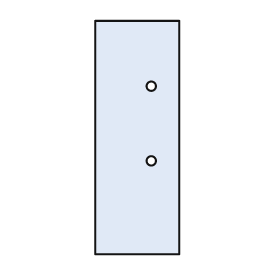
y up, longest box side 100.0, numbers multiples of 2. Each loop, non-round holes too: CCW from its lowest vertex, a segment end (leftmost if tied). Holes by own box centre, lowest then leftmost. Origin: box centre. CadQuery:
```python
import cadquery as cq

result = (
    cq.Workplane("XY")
    .moveTo(-18.0, -50.0)
    .lineTo(18.0, -50.0)
    .lineTo(18.0, 50.0)
    .lineTo(-18.0, 50.0)
    .close()
    .moveTo(6.0, -10.0)
    .circle(2.0)
    .moveTo(6.0, 22.0)
    .circle(2.0)
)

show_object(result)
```